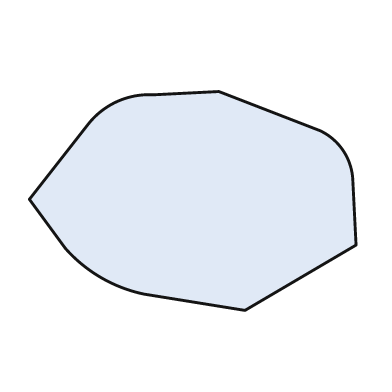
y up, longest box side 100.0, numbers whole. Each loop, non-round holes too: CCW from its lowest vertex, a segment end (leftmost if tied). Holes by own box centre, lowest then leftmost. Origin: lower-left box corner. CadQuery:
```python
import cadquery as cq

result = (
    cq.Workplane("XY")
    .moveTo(66.0, 0.0)
    .lineTo(100.0, 20.0)
    .lineTo(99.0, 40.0)
    .threePointArc((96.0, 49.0), (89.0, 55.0))
    .lineTo(58.0, 67.0)
    .lineTo(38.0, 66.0)
    .threePointArc((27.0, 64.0), (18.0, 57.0))
    .lineTo(0.0, 34.0)
    .lineTo(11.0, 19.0)
    .threePointArc((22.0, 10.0), (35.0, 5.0))
    .close()
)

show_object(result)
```